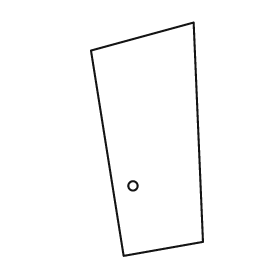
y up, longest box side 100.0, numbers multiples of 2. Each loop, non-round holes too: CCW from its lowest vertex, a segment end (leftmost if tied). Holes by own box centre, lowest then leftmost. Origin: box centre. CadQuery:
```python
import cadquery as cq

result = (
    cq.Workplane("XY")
    .moveTo(-10.0, -50.0)
    .lineTo(24.0, -44.0)
    .lineTo(20.0, 50.0)
    .lineTo(-24.0, 38.0)
    .close()
    .moveTo(-6.0, -20.0)
    .circle(2.0)
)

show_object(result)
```